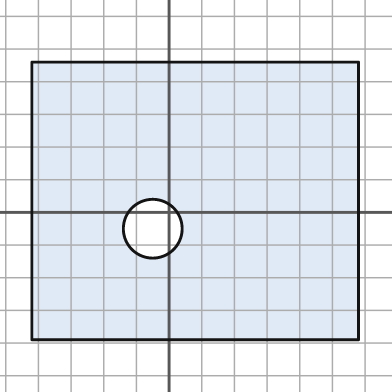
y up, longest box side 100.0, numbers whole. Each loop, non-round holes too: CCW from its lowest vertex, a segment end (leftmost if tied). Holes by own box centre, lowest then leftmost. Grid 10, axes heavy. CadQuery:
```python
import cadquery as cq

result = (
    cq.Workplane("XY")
    .moveTo(-42.0, -39.0)
    .lineTo(58.0, -39.0)
    .lineTo(58.0, 46.0)
    .lineTo(-42.0, 46.0)
    .close()
    .moveTo(-5.0, -5.0)
    .circle(9.0)
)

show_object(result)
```